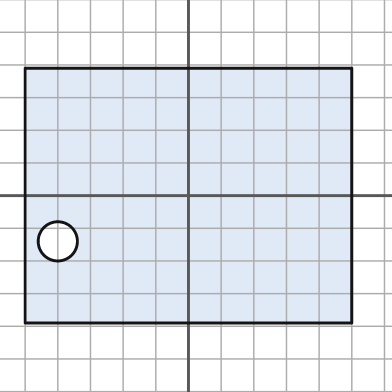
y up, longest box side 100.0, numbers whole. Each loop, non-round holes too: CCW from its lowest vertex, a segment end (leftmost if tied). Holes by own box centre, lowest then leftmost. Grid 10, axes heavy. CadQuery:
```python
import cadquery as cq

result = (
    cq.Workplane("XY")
    .moveTo(-50.0, -39.0)
    .lineTo(50.0, -39.0)
    .lineTo(50.0, 39.0)
    .lineTo(-50.0, 39.0)
    .close()
    .moveTo(-40.0, -14.0)
    .circle(6.0)
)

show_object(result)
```